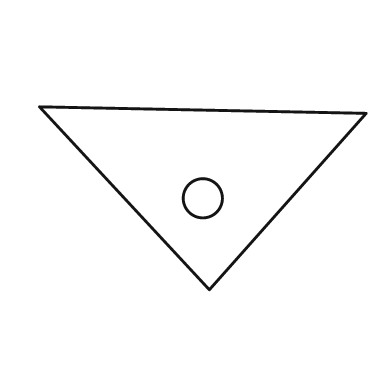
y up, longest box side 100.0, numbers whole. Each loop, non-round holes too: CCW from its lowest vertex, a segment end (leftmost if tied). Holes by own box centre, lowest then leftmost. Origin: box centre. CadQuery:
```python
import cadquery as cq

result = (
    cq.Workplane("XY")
    .moveTo(2.0, -28.0)
    .lineTo(50.0, 26.0)
    .lineTo(-50.0, 28.0)
    .close()
    .moveTo(0.0, 0.0)
    .circle(6.0)
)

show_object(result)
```